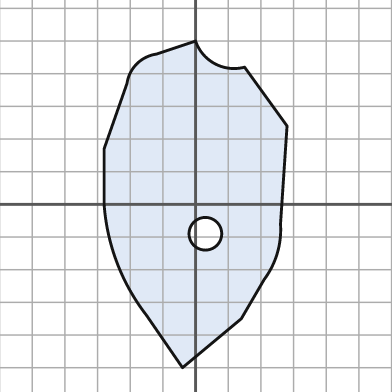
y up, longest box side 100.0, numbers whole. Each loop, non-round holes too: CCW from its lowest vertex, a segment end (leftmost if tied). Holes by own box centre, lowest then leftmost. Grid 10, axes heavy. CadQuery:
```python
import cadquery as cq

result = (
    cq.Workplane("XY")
    .moveTo(-4.0, -50.0)
    .lineTo(14.0, -35.0)
    .lineTo(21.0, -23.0)
    .threePointArc((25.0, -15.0), (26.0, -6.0))
    .lineTo(28.0, 24.0)
    .lineTo(15.0, 42.0)
    .threePointArc((6.0, 43.0), (0.0, 50.0))
    .lineTo(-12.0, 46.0)
    .threePointArc((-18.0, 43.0), (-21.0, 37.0))
    .lineTo(-28.0, 17.0)
    .lineTo(-28.0, 0.0)
    .threePointArc((-24.0, -18.0), (-15.0, -34.0))
    .close()
    .moveTo(3.0, -9.0)
    .circle(5.0)
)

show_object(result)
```